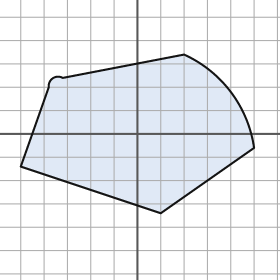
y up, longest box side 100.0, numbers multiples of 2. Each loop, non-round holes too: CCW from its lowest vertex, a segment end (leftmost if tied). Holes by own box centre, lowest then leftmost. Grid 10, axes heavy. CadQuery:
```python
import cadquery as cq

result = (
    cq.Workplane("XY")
    .moveTo(10.0, -34.0)
    .lineTo(50.0, -6.0)
    .threePointArc((40.0, 18.0), (20.0, 34.0))
    .lineTo(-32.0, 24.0)
    .threePointArc((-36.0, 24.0), (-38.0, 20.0))
    .lineTo(-50.0, -14.0)
    .close()
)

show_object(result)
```